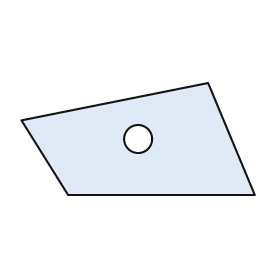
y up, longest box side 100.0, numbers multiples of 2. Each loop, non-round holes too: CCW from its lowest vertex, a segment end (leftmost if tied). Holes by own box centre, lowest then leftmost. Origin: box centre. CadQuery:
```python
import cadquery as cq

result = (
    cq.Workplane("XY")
    .moveTo(-30.0, -24.0)
    .lineTo(50.0, -24.0)
    .lineTo(30.0, 24.0)
    .lineTo(-50.0, 8.0)
    .close()
    .moveTo(0.0, 0.0)
    .circle(6.0)
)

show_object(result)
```